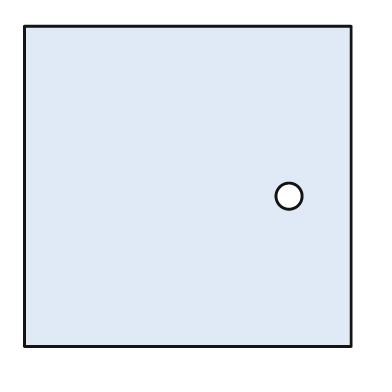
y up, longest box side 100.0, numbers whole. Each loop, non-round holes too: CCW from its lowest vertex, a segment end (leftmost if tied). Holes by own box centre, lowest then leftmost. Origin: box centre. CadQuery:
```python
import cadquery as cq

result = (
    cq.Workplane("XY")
    .moveTo(-50.0, -49.0)
    .lineTo(50.0, -49.0)
    .lineTo(50.0, 49.0)
    .lineTo(-50.0, 49.0)
    .close()
    .moveTo(31.0, -3.0)
    .circle(4.0)
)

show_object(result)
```